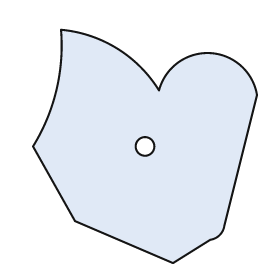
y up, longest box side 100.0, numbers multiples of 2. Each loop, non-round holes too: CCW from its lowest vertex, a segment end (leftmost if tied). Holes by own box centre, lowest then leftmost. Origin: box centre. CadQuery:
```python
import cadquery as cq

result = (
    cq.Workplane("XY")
    .moveTo(12.0, -50.0)
    .lineTo(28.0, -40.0)
    .threePointArc((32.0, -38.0), (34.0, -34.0))
    .lineTo(48.0, 22.0)
    .threePointArc((28.0, 40.0), (6.0, 24.0))
    .threePointArc((-12.0, 42.0), (-36.0, 50.0))
    .threePointArc((-38.0, 24.0), (-48.0, 0.0))
    .lineTo(-30.0, -32.0)
    .close()
    .moveTo(0.0, 0.0)
    .circle(4.0)
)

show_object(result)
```